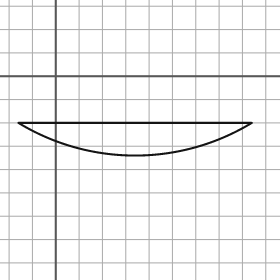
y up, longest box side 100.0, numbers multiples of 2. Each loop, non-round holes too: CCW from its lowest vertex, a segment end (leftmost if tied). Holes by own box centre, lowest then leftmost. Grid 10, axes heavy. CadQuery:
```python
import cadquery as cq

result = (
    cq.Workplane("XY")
    .moveTo(-16.0, -20.0)
    .threePointArc((34.0, -34.0), (84.0, -20.0))
    .close()
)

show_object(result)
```